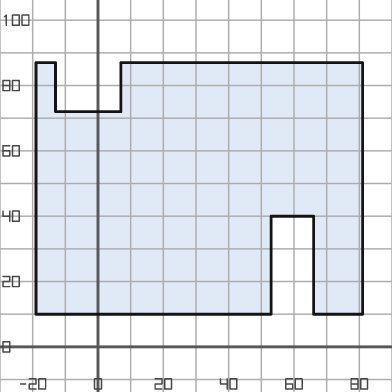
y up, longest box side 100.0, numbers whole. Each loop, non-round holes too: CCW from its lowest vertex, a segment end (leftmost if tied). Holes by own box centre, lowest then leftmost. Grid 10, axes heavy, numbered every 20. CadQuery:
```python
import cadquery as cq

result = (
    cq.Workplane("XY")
    .moveTo(-19.0, 10.0)
    .lineTo(53.0, 10.0)
    .lineTo(53.0, 40.0)
    .lineTo(66.0, 40.0)
    .lineTo(66.0, 10.0)
    .lineTo(81.0, 10.0)
    .lineTo(81.0, 87.0)
    .lineTo(7.0, 87.0)
    .lineTo(7.0, 72.0)
    .lineTo(-13.0, 72.0)
    .lineTo(-13.0, 87.0)
    .lineTo(-19.0, 87.0)
    .close()
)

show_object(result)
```